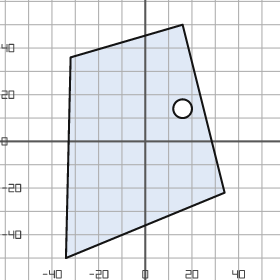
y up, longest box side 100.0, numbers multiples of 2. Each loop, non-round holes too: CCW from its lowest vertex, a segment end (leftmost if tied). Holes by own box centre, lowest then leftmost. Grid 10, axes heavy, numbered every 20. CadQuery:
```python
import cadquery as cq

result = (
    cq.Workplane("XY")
    .moveTo(-34.0, -50.0)
    .lineTo(34.0, -22.0)
    .lineTo(16.0, 50.0)
    .lineTo(-32.0, 36.0)
    .close()
    .moveTo(16.0, 14.0)
    .circle(4.0)
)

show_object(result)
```